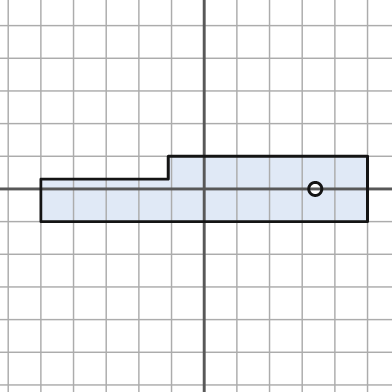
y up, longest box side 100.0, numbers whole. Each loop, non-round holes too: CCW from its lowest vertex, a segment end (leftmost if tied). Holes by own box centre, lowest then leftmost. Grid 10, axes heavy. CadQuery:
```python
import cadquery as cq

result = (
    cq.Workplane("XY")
    .moveTo(-50.0, -10.0)
    .lineTo(50.0, -10.0)
    .lineTo(50.0, 10.0)
    .lineTo(-11.0, 10.0)
    .lineTo(-11.0, 3.0)
    .lineTo(-50.0, 3.0)
    .close()
    .moveTo(34.0, 0.0)
    .circle(2.0)
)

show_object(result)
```